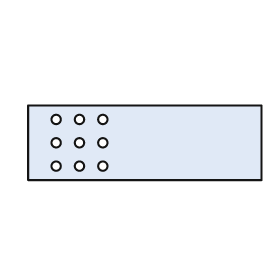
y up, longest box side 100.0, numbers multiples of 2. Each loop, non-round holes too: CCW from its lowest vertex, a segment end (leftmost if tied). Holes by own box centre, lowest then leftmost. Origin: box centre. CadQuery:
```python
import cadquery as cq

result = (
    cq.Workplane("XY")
    .moveTo(-50.0, -16.0)
    .lineTo(50.0, -16.0)
    .lineTo(50.0, 16.0)
    .lineTo(-50.0, 16.0)
    .close()
    .moveTo(-38.0, -10.0)
    .circle(2.0)
    .moveTo(-28.0, -10.0)
    .circle(2.0)
    .moveTo(-18.0, -10.0)
    .circle(2.0)
    .moveTo(-38.0, 0.0)
    .circle(2.0)
    .moveTo(-28.0, 0.0)
    .circle(2.0)
    .moveTo(-18.0, 0.0)
    .circle(2.0)
    .moveTo(-38.0, 10.0)
    .circle(2.0)
    .moveTo(-28.0, 10.0)
    .circle(2.0)
    .moveTo(-18.0, 10.0)
    .circle(2.0)
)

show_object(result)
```